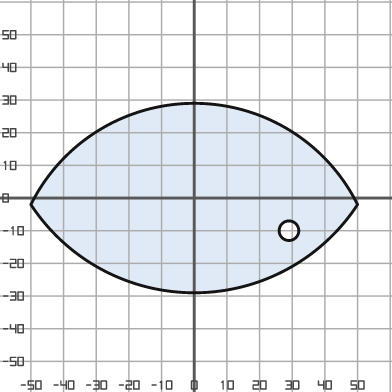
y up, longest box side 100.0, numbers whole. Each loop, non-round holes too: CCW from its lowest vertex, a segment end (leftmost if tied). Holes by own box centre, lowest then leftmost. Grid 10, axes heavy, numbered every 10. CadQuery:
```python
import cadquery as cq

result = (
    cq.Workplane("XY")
    .moveTo(-50.0, -2.0)
    .threePointArc((0.0, -29.0), (50.0, -2.0))
    .threePointArc((0.0, 29.0), (-50.0, -2.0))
    .close()
    .moveTo(29.0, -10.0)
    .circle(3.0)
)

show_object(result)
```